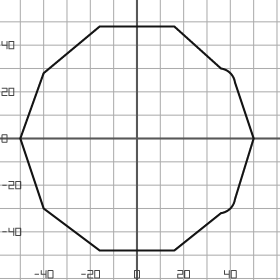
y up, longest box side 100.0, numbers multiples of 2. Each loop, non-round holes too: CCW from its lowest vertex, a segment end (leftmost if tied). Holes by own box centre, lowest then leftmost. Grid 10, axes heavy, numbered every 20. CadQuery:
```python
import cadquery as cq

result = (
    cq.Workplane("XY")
    .moveTo(-16.0, -48.0)
    .lineTo(16.0, -48.0)
    .lineTo(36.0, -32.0)
    .threePointArc((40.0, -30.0), (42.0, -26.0))
    .lineTo(50.0, 0.0)
    .lineTo(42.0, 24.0)
    .threePointArc((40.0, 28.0), (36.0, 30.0))
    .lineTo(16.0, 48.0)
    .lineTo(-16.0, 48.0)
    .lineTo(-40.0, 28.0)
    .lineTo(-50.0, 0.0)
    .lineTo(-40.0, -30.0)
    .close()
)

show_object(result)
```